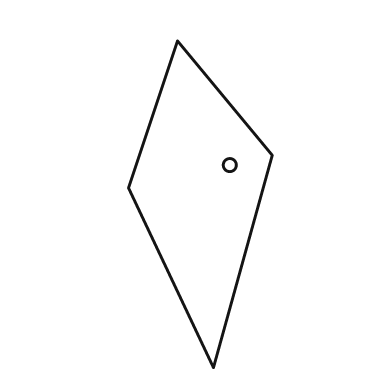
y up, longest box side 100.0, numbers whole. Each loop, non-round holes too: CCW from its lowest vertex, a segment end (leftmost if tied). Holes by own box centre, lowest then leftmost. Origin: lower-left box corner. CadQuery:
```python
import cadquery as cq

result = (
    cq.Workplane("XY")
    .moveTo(26.0, 0.0)
    .lineTo(44.0, 65.0)
    .lineTo(15.0, 100.0)
    .lineTo(0.0, 55.0)
    .close()
    .moveTo(31.0, 62.0)
    .circle(2.0)
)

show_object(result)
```